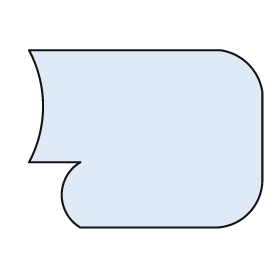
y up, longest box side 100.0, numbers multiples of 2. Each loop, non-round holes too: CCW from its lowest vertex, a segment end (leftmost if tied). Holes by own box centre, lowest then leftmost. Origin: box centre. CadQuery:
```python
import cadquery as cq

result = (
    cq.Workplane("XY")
    .moveTo(-28.0, -38.0)
    .lineTo(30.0, -38.0)
    .threePointArc((44.0, -32.0), (50.0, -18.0))
    .lineTo(50.0, 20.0)
    .threePointArc((44.0, 32.0), (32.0, 38.0))
    .lineTo(-50.0, 38.0)
    .threePointArc((-44.0, 14.0), (-50.0, -10.0))
    .lineTo(-28.0, -10.0)
    .threePointArc((-36.0, -24.0), (-28.0, -38.0))
    .close()
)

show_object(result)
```